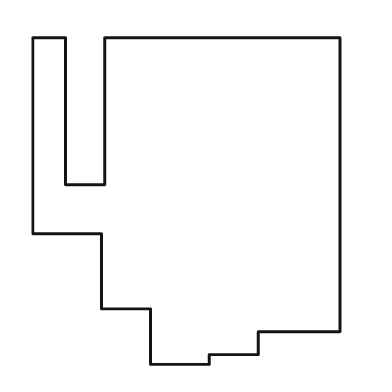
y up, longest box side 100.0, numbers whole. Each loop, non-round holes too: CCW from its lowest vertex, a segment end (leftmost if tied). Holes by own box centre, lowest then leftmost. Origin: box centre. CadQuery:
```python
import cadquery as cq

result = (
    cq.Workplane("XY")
    .moveTo(-11.0, -50.0)
    .lineTo(7.0, -50.0)
    .lineTo(7.0, -47.0)
    .lineTo(22.0, -47.0)
    .lineTo(22.0, -40.0)
    .lineTo(47.0, -40.0)
    .lineTo(47.0, 50.0)
    .lineTo(-25.0, 50.0)
    .lineTo(-25.0, 5.0)
    .lineTo(-37.0, 5.0)
    .lineTo(-37.0, 50.0)
    .lineTo(-47.0, 50.0)
    .lineTo(-47.0, -10.0)
    .lineTo(-26.0, -10.0)
    .lineTo(-26.0, -33.0)
    .lineTo(-11.0, -33.0)
    .close()
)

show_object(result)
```